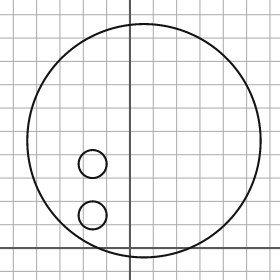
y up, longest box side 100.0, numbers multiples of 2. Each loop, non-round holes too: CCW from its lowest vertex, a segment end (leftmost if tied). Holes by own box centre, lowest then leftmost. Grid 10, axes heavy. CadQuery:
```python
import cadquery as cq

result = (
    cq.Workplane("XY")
    .moveTo(6.0, 46.0)
    .circle(50.0)
    .moveTo(-16.0, 14.0)
    .circle(6.0)
    .moveTo(-16.0, 36.0)
    .circle(6.0)
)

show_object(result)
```